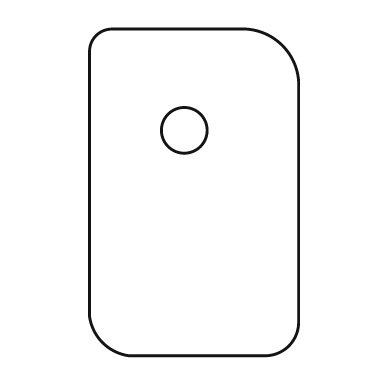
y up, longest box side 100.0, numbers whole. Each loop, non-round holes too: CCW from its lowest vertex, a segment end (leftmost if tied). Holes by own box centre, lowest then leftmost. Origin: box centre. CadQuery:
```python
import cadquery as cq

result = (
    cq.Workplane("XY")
    .moveTo(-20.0, -50.0)
    .lineTo(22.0, -50.0)
    .threePointArc((29.0, -47.0), (32.0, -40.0))
    .lineTo(32.0, 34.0)
    .threePointArc((27.0, 45.0), (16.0, 50.0))
    .lineTo(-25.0, 50.0)
    .threePointArc((-30.0, 48.0), (-32.0, 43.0))
    .lineTo(-32.0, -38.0)
    .threePointArc((-28.0, -46.0), (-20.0, -50.0))
    .close()
    .moveTo(-3.0, 19.0)
    .circle(7.0)
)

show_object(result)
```